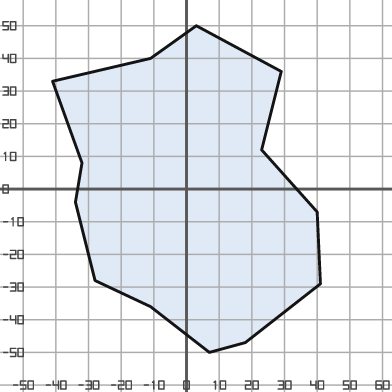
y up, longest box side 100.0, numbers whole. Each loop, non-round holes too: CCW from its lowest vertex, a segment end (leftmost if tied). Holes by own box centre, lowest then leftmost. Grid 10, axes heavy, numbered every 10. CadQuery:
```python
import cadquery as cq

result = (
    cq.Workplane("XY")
    .moveTo(7.0, -50.0)
    .lineTo(18.0, -47.0)
    .lineTo(41.0, -29.0)
    .lineTo(40.0, -7.0)
    .lineTo(23.0, 12.0)
    .lineTo(29.0, 36.0)
    .lineTo(3.0, 50.0)
    .lineTo(-11.0, 40.0)
    .lineTo(-41.0, 33.0)
    .lineTo(-32.0, 8.0)
    .lineTo(-34.0, -4.0)
    .lineTo(-28.0, -28.0)
    .lineTo(-11.0, -36.0)
    .close()
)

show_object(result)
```